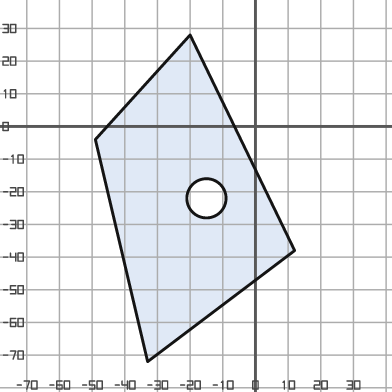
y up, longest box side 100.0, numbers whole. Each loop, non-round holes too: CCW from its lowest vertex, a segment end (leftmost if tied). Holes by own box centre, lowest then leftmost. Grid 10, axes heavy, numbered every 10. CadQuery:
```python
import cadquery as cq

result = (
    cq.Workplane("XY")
    .moveTo(-33.0, -72.0)
    .lineTo(12.0, -38.0)
    .lineTo(-20.0, 28.0)
    .lineTo(-49.0, -4.0)
    .close()
    .moveTo(-15.0, -22.0)
    .circle(6.0)
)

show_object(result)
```